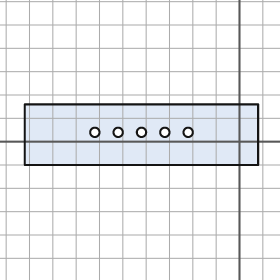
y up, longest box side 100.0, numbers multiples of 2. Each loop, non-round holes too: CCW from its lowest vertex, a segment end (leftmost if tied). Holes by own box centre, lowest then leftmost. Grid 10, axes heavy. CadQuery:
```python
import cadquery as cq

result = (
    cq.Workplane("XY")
    .moveTo(-92.0, -10.0)
    .lineTo(8.0, -10.0)
    .lineTo(8.0, 16.0)
    .lineTo(-92.0, 16.0)
    .close()
    .moveTo(-62.0, 4.0)
    .circle(2.0)
    .moveTo(-52.0, 4.0)
    .circle(2.0)
    .moveTo(-42.0, 4.0)
    .circle(2.0)
    .moveTo(-32.0, 4.0)
    .circle(2.0)
    .moveTo(-22.0, 4.0)
    .circle(2.0)
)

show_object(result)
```